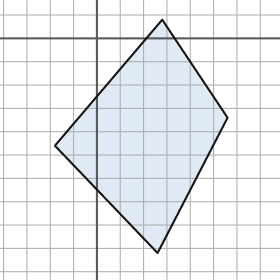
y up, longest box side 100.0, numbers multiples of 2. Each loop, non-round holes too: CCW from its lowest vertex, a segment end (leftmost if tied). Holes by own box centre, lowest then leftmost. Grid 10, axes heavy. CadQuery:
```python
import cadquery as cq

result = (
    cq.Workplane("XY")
    .moveTo(26.0, -92.0)
    .lineTo(56.0, -34.0)
    .lineTo(28.0, 8.0)
    .lineTo(-18.0, -46.0)
    .close()
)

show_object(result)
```